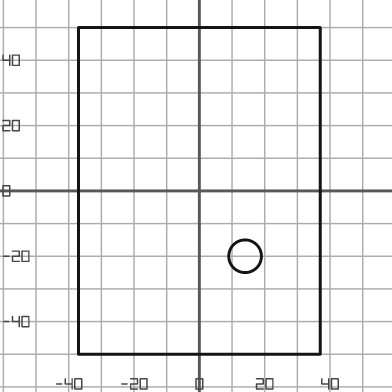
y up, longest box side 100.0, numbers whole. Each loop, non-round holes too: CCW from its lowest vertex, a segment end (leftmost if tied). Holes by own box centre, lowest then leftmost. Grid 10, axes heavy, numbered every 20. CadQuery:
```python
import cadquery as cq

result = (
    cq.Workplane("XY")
    .moveTo(-37.0, -50.0)
    .lineTo(37.0, -50.0)
    .lineTo(37.0, 50.0)
    .lineTo(-37.0, 50.0)
    .close()
    .moveTo(14.0, -20.0)
    .circle(5.0)
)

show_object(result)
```